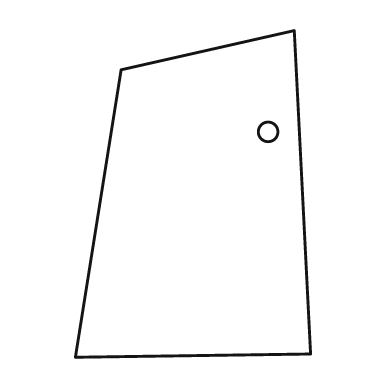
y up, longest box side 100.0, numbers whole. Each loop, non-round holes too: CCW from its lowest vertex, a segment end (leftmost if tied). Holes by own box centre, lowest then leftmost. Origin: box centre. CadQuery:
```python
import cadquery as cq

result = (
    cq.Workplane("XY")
    .moveTo(-36.0, -50.0)
    .lineTo(36.0, -49.0)
    .lineTo(31.0, 50.0)
    .lineTo(-22.0, 38.0)
    .close()
    .moveTo(23.0, 19.0)
    .circle(3.0)
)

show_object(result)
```